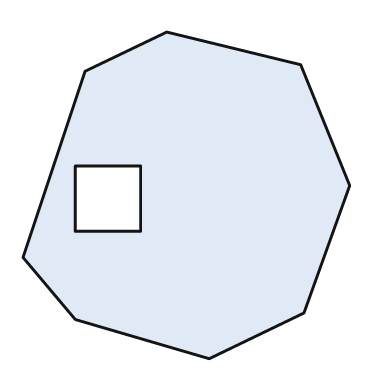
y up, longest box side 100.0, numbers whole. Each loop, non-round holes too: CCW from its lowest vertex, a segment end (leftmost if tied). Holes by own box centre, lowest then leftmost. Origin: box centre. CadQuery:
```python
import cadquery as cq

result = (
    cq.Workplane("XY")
    .moveTo(7.0, -50.0)
    .lineTo(36.0, -36.0)
    .lineTo(50.0, 3.0)
    .lineTo(35.0, 40.0)
    .lineTo(-6.0, 50.0)
    .lineTo(-31.0, 38.0)
    .lineTo(-50.0, -19.0)
    .lineTo(-34.0, -38.0)
    .close()
    .moveTo(-34.0, -11.0)
    .lineTo(-14.0, -11.0)
    .lineTo(-14.0, 9.0)
    .lineTo(-34.0, 9.0)
    .close()
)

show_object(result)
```